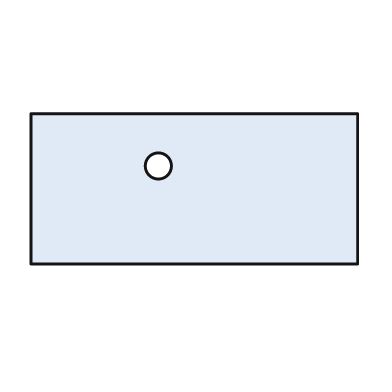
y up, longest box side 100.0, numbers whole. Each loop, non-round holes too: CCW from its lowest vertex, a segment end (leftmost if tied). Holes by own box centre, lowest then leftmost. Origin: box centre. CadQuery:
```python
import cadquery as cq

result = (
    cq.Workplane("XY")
    .moveTo(-50.0, -23.0)
    .lineTo(50.0, -23.0)
    .lineTo(50.0, 23.0)
    .lineTo(-50.0, 23.0)
    .close()
    .moveTo(-11.0, 7.0)
    .circle(4.0)
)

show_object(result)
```